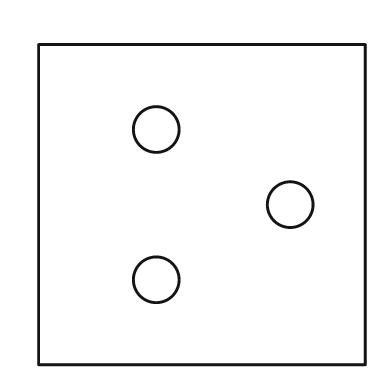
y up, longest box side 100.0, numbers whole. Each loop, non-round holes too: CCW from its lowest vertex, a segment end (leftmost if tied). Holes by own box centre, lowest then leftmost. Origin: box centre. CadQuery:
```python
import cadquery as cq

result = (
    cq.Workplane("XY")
    .moveTo(-50.0, -49.0)
    .lineTo(50.0, -49.0)
    .lineTo(50.0, 49.0)
    .lineTo(-50.0, 49.0)
    .close()
    .moveTo(-14.0, -23.0)
    .circle(7.0)
    .moveTo(27.0, 0.0)
    .circle(7.0)
    .moveTo(-14.0, 23.0)
    .circle(7.0)
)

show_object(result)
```